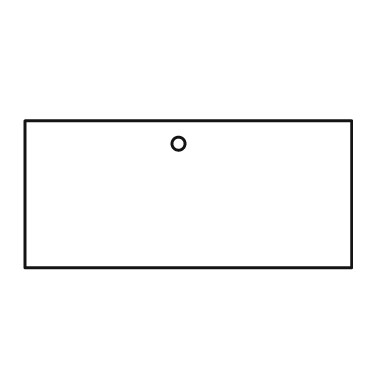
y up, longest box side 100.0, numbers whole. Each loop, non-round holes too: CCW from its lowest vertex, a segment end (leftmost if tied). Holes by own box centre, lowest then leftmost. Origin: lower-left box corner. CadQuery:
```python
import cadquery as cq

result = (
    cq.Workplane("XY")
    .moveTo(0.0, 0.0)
    .lineTo(100.0, 0.0)
    .lineTo(100.0, 45.0)
    .lineTo(0.0, 45.0)
    .close()
    .moveTo(47.0, 38.0)
    .circle(2.0)
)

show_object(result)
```